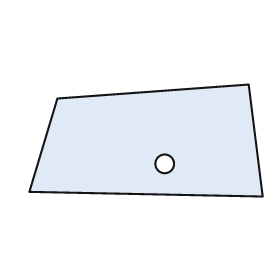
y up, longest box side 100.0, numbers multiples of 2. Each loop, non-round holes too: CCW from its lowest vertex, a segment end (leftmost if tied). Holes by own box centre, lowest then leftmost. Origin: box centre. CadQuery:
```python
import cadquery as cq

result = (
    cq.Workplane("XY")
    .moveTo(50.0, -24.0)
    .lineTo(44.0, 24.0)
    .lineTo(-38.0, 18.0)
    .lineTo(-50.0, -22.0)
    .close()
    .moveTo(8.0, -10.0)
    .circle(4.0)
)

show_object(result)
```